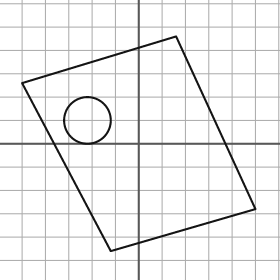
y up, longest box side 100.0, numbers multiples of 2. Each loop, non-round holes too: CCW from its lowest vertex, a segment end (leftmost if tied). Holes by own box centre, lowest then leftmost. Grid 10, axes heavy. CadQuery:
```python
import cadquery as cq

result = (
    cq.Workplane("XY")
    .moveTo(-12.0, -46.0)
    .lineTo(50.0, -28.0)
    .lineTo(16.0, 46.0)
    .lineTo(-50.0, 26.0)
    .close()
    .moveTo(-22.0, 10.0)
    .circle(10.0)
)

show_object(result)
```